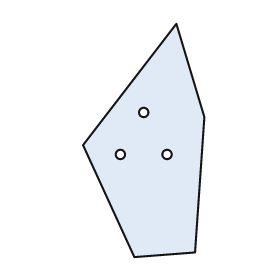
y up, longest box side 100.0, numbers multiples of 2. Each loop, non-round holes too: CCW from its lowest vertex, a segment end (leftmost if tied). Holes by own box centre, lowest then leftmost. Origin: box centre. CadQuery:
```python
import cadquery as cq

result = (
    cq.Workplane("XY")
    .moveTo(-4.0, -50.0)
    .lineTo(22.0, -48.0)
    .lineTo(26.0, 10.0)
    .lineTo(14.0, 50.0)
    .lineTo(-26.0, -2.0)
    .close()
    .moveTo(-10.0, -6.0)
    .circle(2.0)
    .moveTo(10.0, -6.0)
    .circle(2.0)
    .moveTo(0.0, 12.0)
    .circle(2.0)
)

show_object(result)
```